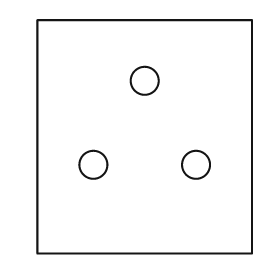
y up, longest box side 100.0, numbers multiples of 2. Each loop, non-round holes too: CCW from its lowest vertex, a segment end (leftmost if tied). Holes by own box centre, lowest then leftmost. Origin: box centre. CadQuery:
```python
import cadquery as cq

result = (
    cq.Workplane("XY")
    .moveTo(-46.0, -50.0)
    .lineTo(46.0, -50.0)
    .lineTo(46.0, 50.0)
    .lineTo(-46.0, 50.0)
    .close()
    .moveTo(-22.0, -12.0)
    .circle(6.0)
    .moveTo(22.0, -12.0)
    .circle(6.0)
    .moveTo(0.0, 24.0)
    .circle(6.0)
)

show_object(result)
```